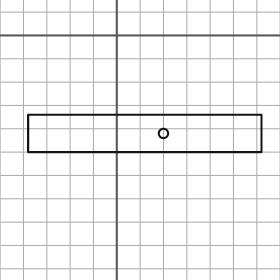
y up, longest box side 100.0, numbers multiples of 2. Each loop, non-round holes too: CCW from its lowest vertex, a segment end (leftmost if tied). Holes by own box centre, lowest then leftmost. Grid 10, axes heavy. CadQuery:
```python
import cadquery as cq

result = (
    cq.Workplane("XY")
    .moveTo(-38.0, -50.0)
    .lineTo(62.0, -50.0)
    .lineTo(62.0, -34.0)
    .lineTo(-38.0, -34.0)
    .close()
    .moveTo(20.0, -42.0)
    .circle(2.0)
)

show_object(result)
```